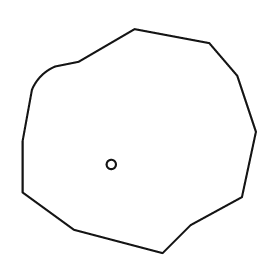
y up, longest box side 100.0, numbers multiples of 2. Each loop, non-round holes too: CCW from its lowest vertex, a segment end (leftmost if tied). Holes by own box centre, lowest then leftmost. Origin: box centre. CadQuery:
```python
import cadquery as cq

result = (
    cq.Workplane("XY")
    .moveTo(10.0, -48.0)
    .lineTo(22.0, -36.0)
    .lineTo(44.0, -24.0)
    .lineTo(50.0, 4.0)
    .lineTo(42.0, 28.0)
    .lineTo(30.0, 42.0)
    .lineTo(-2.0, 48.0)
    .lineTo(-26.0, 34.0)
    .lineTo(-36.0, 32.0)
    .threePointArc((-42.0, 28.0), (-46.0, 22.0))
    .lineTo(-50.0, 0.0)
    .lineTo(-50.0, -22.0)
    .lineTo(-28.0, -38.0)
    .close()
    .moveTo(-12.0, -10.0)
    .circle(2.0)
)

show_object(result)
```